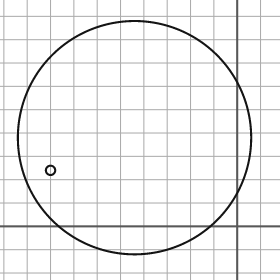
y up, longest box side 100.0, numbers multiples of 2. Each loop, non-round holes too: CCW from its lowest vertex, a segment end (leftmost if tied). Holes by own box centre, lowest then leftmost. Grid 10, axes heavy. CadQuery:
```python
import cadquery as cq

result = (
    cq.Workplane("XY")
    .moveTo(-44.0, 38.0)
    .circle(50.0)
    .moveTo(-80.0, 24.0)
    .circle(2.0)
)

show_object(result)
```